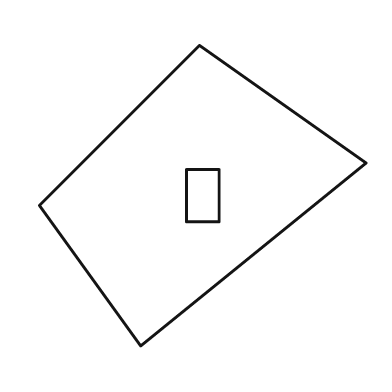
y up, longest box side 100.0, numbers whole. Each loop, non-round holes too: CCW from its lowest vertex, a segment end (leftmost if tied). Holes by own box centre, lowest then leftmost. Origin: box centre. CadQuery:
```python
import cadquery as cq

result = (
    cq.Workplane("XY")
    .moveTo(-19.0, -46.0)
    .lineTo(50.0, 10.0)
    .lineTo(-1.0, 46.0)
    .lineTo(-50.0, -3.0)
    .close()
    .moveTo(-5.0, -8.0)
    .lineTo(5.0, -8.0)
    .lineTo(5.0, 8.0)
    .lineTo(-5.0, 8.0)
    .close()
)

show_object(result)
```